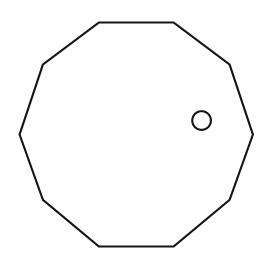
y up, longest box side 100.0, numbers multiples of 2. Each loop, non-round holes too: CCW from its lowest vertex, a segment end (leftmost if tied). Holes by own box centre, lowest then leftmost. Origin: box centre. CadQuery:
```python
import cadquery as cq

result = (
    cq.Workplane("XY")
    .moveTo(-16.0, -48.0)
    .lineTo(16.0, -48.0)
    .lineTo(40.0, -28.0)
    .lineTo(50.0, 0.0)
    .lineTo(40.0, 30.0)
    .lineTo(16.0, 48.0)
    .lineTo(-16.0, 48.0)
    .lineTo(-40.0, 30.0)
    .lineTo(-50.0, 0.0)
    .lineTo(-40.0, -28.0)
    .close()
    .moveTo(28.0, 6.0)
    .circle(4.0)
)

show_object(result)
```